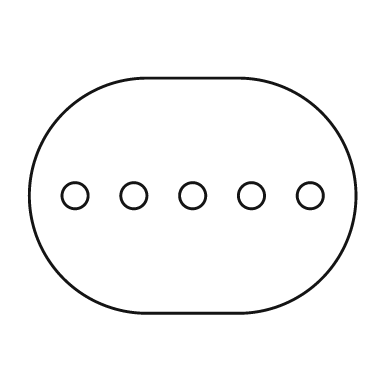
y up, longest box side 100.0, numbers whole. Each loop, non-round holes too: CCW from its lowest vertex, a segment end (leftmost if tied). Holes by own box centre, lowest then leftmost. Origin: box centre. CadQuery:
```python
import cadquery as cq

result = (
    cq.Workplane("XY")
    .moveTo(-14.0, -36.0)
    .lineTo(14.0, -36.0)
    .threePointArc((50.0, 0.0), (14.0, 36.0))
    .lineTo(-14.0, 36.0)
    .threePointArc((-50.0, 0.0), (-14.0, -36.0))
    .close()
    .moveTo(-36.0, 0.0)
    .circle(4.0)
    .moveTo(-18.0, 0.0)
    .circle(4.0)
    .moveTo(0.0, 0.0)
    .circle(4.0)
    .moveTo(18.0, 0.0)
    .circle(4.0)
    .moveTo(36.0, 0.0)
    .circle(4.0)
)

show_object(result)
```